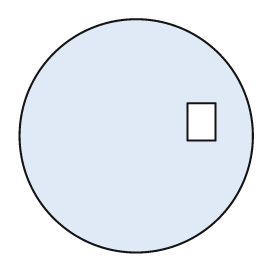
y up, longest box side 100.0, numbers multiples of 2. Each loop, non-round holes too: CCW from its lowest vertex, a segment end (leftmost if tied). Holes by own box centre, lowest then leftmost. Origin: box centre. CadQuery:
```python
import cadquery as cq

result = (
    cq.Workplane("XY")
    .moveTo(0.0, 0.0)
    .circle(50.0)
    .moveTo(22.0, -2.0)
    .lineTo(34.0, -2.0)
    .lineTo(34.0, 14.0)
    .lineTo(22.0, 14.0)
    .close()
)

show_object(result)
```